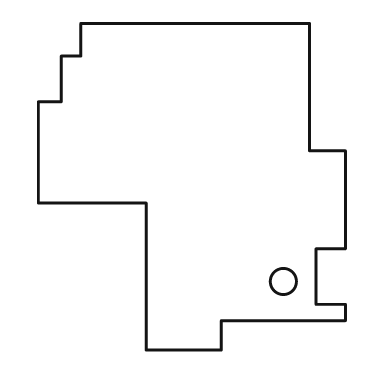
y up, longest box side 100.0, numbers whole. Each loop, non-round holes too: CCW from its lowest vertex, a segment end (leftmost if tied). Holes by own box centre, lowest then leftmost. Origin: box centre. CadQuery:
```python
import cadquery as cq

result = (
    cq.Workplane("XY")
    .moveTo(-14.0, -50.0)
    .lineTo(9.0, -50.0)
    .lineTo(9.0, -41.0)
    .lineTo(47.0, -41.0)
    .lineTo(47.0, -36.0)
    .lineTo(38.0, -36.0)
    .lineTo(38.0, -19.0)
    .lineTo(47.0, -19.0)
    .lineTo(47.0, 11.0)
    .lineTo(36.0, 11.0)
    .lineTo(36.0, 50.0)
    .lineTo(-34.0, 50.0)
    .lineTo(-34.0, 40.0)
    .lineTo(-40.0, 40.0)
    .lineTo(-40.0, 26.0)
    .lineTo(-47.0, 26.0)
    .lineTo(-47.0, -5.0)
    .lineTo(-14.0, -5.0)
    .close()
    .moveTo(28.0, -29.0)
    .circle(4.0)
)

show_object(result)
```